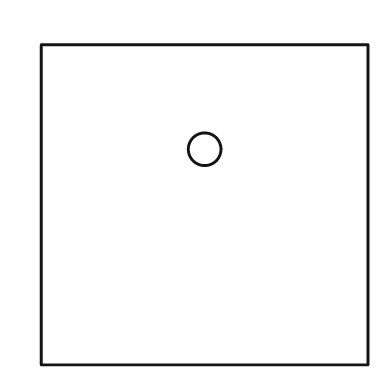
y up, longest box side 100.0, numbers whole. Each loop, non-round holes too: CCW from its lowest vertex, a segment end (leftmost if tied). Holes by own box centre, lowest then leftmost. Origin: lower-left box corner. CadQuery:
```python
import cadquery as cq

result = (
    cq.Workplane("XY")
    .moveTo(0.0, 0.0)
    .lineTo(100.0, 0.0)
    .lineTo(100.0, 98.0)
    .lineTo(0.0, 98.0)
    .close()
    .moveTo(50.0, 66.0)
    .circle(5.0)
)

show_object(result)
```